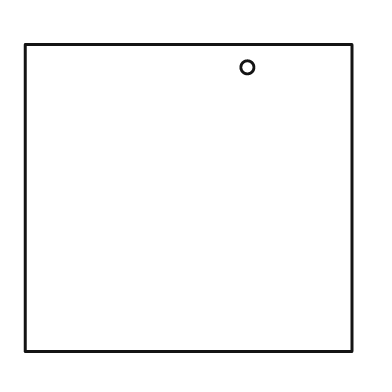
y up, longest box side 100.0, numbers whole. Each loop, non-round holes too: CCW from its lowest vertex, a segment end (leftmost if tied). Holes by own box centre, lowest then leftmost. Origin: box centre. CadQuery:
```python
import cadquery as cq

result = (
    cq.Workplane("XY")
    .moveTo(-50.0, -47.0)
    .lineTo(50.0, -47.0)
    .lineTo(50.0, 47.0)
    .lineTo(-50.0, 47.0)
    .close()
    .moveTo(18.0, 40.0)
    .circle(2.0)
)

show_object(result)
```